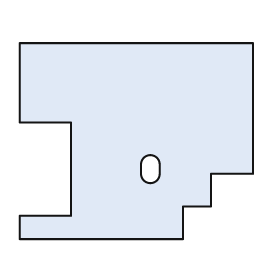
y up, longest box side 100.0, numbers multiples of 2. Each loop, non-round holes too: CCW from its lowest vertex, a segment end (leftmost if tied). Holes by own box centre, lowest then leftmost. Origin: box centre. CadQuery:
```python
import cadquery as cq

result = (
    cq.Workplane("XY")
    .moveTo(-50.0, -42.0)
    .lineTo(20.0, -42.0)
    .lineTo(20.0, -28.0)
    .lineTo(32.0, -28.0)
    .lineTo(32.0, -14.0)
    .lineTo(50.0, -14.0)
    .lineTo(50.0, 42.0)
    .lineTo(-50.0, 42.0)
    .lineTo(-50.0, 8.0)
    .lineTo(-28.0, 8.0)
    .lineTo(-28.0, -32.0)
    .lineTo(-50.0, -32.0)
    .close()
    .moveTo(2.0, -14.0)
    .threePointArc((6.0, -18.0), (10.0, -14.0))
    .lineTo(10.0, -10.0)
    .threePointArc((6.0, -6.0), (2.0, -10.0))
    .close()
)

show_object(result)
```